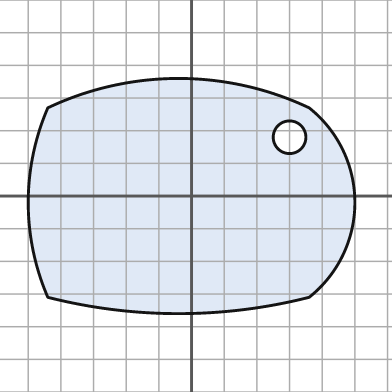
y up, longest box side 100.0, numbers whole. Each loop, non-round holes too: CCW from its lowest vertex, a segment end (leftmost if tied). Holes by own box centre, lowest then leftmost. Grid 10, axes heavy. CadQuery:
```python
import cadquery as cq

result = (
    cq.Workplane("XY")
    .moveTo(-44.0, -31.0)
    .threePointArc((-4.0, -36.0), (36.0, -31.0))
    .threePointArc((50.0, -2.0), (36.0, 27.0))
    .threePointArc((-4.0, 36.0), (-44.0, 27.0))
    .threePointArc((-50.0, -2.0), (-44.0, -31.0))
    .close()
    .moveTo(30.0, 18.0)
    .circle(5.0)
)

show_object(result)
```